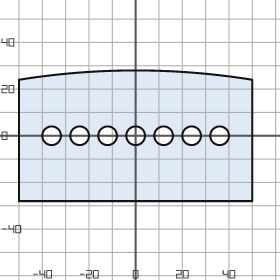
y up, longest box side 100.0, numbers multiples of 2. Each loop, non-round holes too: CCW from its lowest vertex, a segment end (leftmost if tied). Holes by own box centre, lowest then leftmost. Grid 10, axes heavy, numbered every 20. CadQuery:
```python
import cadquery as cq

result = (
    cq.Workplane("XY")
    .moveTo(-50.0, -28.0)
    .lineTo(50.0, -28.0)
    .lineTo(50.0, 24.0)
    .threePointArc((0.0, 28.0), (-50.0, 24.0))
    .close()
    .moveTo(-36.0, 0.0)
    .circle(4.0)
    .moveTo(-24.0, 0.0)
    .circle(4.0)
    .moveTo(-12.0, 0.0)
    .circle(4.0)
    .moveTo(0.0, 0.0)
    .circle(4.0)
    .moveTo(12.0, 0.0)
    .circle(4.0)
    .moveTo(24.0, 0.0)
    .circle(4.0)
    .moveTo(36.0, 0.0)
    .circle(4.0)
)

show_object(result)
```